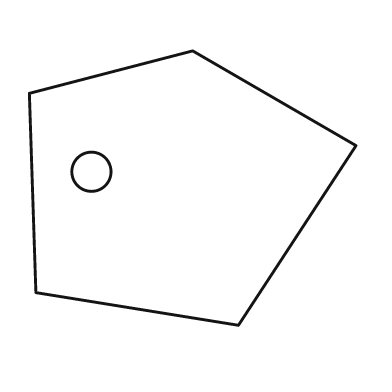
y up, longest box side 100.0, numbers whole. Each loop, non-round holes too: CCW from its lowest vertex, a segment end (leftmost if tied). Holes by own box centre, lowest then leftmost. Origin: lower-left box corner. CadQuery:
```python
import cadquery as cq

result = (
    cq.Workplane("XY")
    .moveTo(64.0, 0.0)
    .lineTo(100.0, 55.0)
    .lineTo(50.0, 84.0)
    .lineTo(0.0, 71.0)
    .lineTo(2.0, 10.0)
    .close()
    .moveTo(19.0, 47.0)
    .circle(6.0)
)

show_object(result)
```